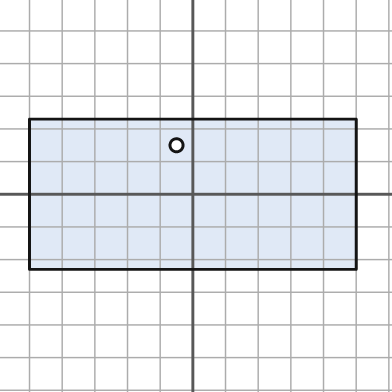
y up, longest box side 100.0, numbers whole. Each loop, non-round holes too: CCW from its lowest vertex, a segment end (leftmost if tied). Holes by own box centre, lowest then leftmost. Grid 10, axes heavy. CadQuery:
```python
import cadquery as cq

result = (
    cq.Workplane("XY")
    .moveTo(-50.0, -23.0)
    .lineTo(50.0, -23.0)
    .lineTo(50.0, 23.0)
    .lineTo(-50.0, 23.0)
    .close()
    .moveTo(-5.0, 15.0)
    .circle(2.0)
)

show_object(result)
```